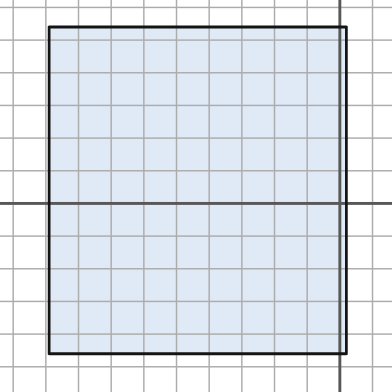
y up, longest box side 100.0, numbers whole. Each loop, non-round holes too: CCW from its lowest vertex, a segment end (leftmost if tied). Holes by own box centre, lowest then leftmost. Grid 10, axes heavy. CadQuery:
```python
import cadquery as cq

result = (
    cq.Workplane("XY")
    .moveTo(-89.0, -46.0)
    .lineTo(2.0, -46.0)
    .lineTo(2.0, 54.0)
    .lineTo(-89.0, 54.0)
    .close()
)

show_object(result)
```